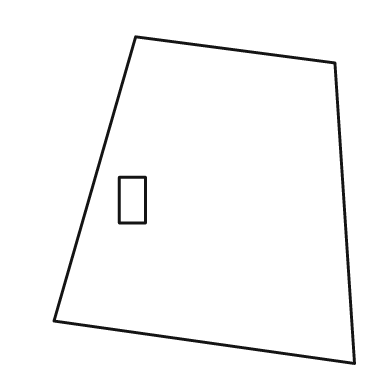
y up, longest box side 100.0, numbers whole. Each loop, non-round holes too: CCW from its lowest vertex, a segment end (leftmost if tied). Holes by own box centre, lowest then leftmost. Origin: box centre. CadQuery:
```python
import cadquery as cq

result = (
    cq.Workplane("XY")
    .moveTo(46.0, -50.0)
    .lineTo(40.0, 42.0)
    .lineTo(-21.0, 50.0)
    .lineTo(-46.0, -37.0)
    .close()
    .moveTo(-26.0, -7.0)
    .lineTo(-18.0, -7.0)
    .lineTo(-18.0, 7.0)
    .lineTo(-26.0, 7.0)
    .close()
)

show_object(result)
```